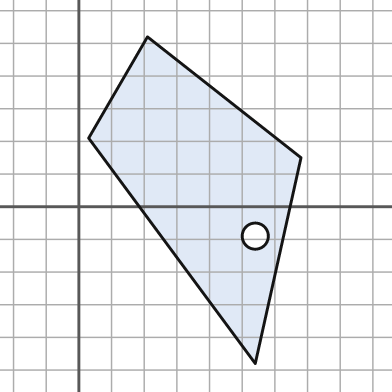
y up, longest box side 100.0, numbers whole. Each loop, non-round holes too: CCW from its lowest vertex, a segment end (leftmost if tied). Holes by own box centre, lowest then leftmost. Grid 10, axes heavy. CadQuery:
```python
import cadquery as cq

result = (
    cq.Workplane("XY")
    .moveTo(54.0, -48.0)
    .lineTo(68.0, 15.0)
    .lineTo(21.0, 52.0)
    .lineTo(3.0, 21.0)
    .close()
    .moveTo(54.0, -9.0)
    .circle(4.0)
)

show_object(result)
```